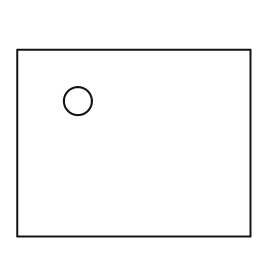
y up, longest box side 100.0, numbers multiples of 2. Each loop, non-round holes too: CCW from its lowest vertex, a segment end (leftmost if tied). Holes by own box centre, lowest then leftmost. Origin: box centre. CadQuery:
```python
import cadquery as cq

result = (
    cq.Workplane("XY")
    .moveTo(-50.0, -40.0)
    .lineTo(50.0, -40.0)
    .lineTo(50.0, 40.0)
    .lineTo(-50.0, 40.0)
    .close()
    .moveTo(-24.0, 18.0)
    .circle(6.0)
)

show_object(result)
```